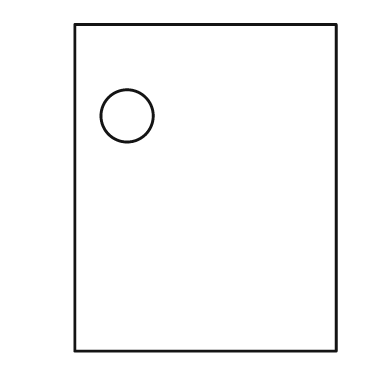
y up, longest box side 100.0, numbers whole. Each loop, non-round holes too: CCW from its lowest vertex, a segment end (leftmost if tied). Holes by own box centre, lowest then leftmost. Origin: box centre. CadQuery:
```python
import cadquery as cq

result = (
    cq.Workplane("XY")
    .moveTo(-40.0, -50.0)
    .lineTo(40.0, -50.0)
    .lineTo(40.0, 50.0)
    .lineTo(-40.0, 50.0)
    .close()
    .moveTo(-24.0, 22.0)
    .circle(8.0)
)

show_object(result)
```